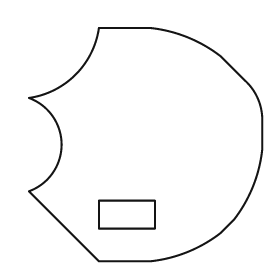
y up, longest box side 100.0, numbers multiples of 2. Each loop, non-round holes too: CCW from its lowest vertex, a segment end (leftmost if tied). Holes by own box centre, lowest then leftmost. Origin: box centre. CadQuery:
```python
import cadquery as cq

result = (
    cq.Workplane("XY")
    .moveTo(-20.0, -50.0)
    .lineTo(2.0, -50.0)
    .threePointArc((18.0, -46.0), (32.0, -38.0))
    .lineTo(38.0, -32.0)
    .threePointArc((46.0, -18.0), (50.0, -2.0))
    .lineTo(50.0, 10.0)
    .threePointArc((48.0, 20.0), (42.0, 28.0))
    .lineTo(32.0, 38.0)
    .threePointArc((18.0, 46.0), (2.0, 50.0))
    .lineTo(-20.0, 50.0)
    .threePointArc((-30.0, 30.0), (-50.0, 20.0))
    .threePointArc((-36.0, 0.0), (-50.0, -20.0))
    .close()
    .moveTo(-20.0, -36.0)
    .lineTo(4.0, -36.0)
    .lineTo(4.0, -24.0)
    .lineTo(-20.0, -24.0)
    .close()
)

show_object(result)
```